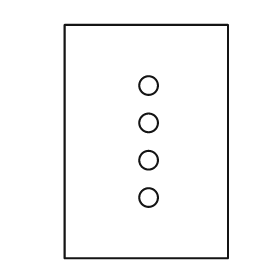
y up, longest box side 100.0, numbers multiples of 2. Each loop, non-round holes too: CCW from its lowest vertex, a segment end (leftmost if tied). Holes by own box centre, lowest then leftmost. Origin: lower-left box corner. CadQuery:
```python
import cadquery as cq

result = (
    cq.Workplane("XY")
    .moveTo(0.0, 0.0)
    .lineTo(70.0, 0.0)
    .lineTo(70.0, 100.0)
    .lineTo(0.0, 100.0)
    .close()
    .moveTo(36.0, 26.0)
    .circle(4.0)
    .moveTo(36.0, 42.0)
    .circle(4.0)
    .moveTo(36.0, 58.0)
    .circle(4.0)
    .moveTo(36.0, 74.0)
    .circle(4.0)
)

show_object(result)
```